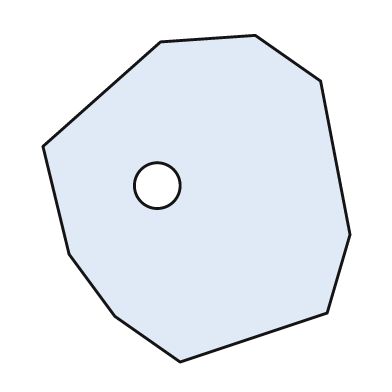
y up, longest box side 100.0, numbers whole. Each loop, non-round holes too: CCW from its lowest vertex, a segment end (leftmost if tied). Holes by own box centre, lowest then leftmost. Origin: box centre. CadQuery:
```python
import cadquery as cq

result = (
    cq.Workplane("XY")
    .moveTo(-5.0, -50.0)
    .lineTo(40.0, -35.0)
    .lineTo(47.0, -11.0)
    .lineTo(38.0, 36.0)
    .lineTo(18.0, 50.0)
    .lineTo(-11.0, 48.0)
    .lineTo(-47.0, 16.0)
    .lineTo(-39.0, -17.0)
    .lineTo(-25.0, -36.0)
    .close()
    .moveTo(-12.0, 4.0)
    .circle(7.0)
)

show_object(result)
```